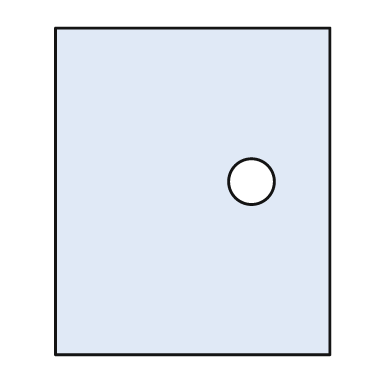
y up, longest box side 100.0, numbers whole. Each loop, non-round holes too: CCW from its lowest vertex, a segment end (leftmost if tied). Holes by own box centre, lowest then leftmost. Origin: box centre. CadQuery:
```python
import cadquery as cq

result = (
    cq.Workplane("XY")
    .moveTo(-42.0, -50.0)
    .lineTo(42.0, -50.0)
    .lineTo(42.0, 50.0)
    .lineTo(-42.0, 50.0)
    .close()
    .moveTo(18.0, 3.0)
    .circle(7.0)
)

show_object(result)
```